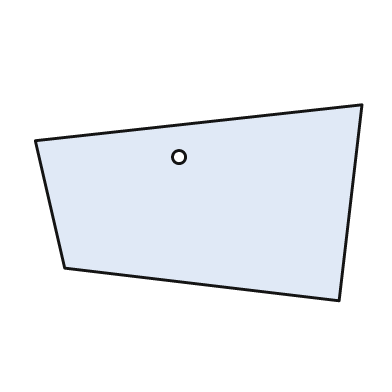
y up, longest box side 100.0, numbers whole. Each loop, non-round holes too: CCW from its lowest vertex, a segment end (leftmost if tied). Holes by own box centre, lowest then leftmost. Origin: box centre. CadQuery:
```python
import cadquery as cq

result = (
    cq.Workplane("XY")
    .moveTo(43.0, -30.0)
    .lineTo(50.0, 30.0)
    .lineTo(-50.0, 19.0)
    .lineTo(-41.0, -20.0)
    .close()
    .moveTo(-6.0, 14.0)
    .circle(2.0)
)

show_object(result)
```